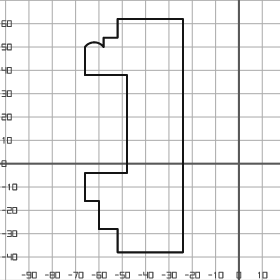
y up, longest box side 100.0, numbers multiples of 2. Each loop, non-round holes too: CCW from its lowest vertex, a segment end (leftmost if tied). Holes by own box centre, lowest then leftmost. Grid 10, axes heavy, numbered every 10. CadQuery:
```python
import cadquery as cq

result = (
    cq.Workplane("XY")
    .moveTo(-52.0, -38.0)
    .lineTo(-24.0, -38.0)
    .lineTo(-24.0, 62.0)
    .lineTo(-52.0, 62.0)
    .lineTo(-52.0, 54.0)
    .lineTo(-58.0, 54.0)
    .lineTo(-58.0, 50.0)
    .threePointArc((-62.0, 52.0), (-66.0, 50.0))
    .lineTo(-66.0, 38.0)
    .lineTo(-48.0, 38.0)
    .lineTo(-48.0, -4.0)
    .lineTo(-66.0, -4.0)
    .lineTo(-66.0, -16.0)
    .lineTo(-60.0, -16.0)
    .lineTo(-60.0, -28.0)
    .lineTo(-52.0, -28.0)
    .close()
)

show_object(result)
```